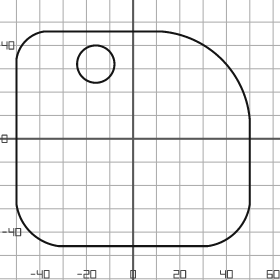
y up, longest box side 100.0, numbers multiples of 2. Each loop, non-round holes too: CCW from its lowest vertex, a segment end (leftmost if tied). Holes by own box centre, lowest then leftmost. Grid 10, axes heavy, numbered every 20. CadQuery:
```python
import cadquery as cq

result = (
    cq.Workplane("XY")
    .moveTo(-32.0, -46.0)
    .lineTo(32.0, -46.0)
    .threePointArc((44.0, -40.0), (50.0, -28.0))
    .lineTo(50.0, 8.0)
    .threePointArc((38.0, 34.0), (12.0, 46.0))
    .lineTo(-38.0, 46.0)
    .threePointArc((-46.0, 42.0), (-50.0, 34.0))
    .lineTo(-50.0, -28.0)
    .threePointArc((-44.0, -40.0), (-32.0, -46.0))
    .close()
    .moveTo(-16.0, 32.0)
    .circle(8.0)
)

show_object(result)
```